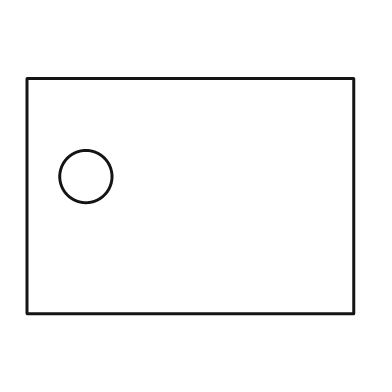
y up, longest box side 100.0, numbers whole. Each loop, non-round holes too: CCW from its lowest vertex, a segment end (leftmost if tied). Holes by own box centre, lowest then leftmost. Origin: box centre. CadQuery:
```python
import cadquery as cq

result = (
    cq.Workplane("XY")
    .moveTo(-50.0, -36.0)
    .lineTo(50.0, -36.0)
    .lineTo(50.0, 36.0)
    .lineTo(-50.0, 36.0)
    .close()
    .moveTo(-32.0, 6.0)
    .circle(8.0)
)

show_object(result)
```